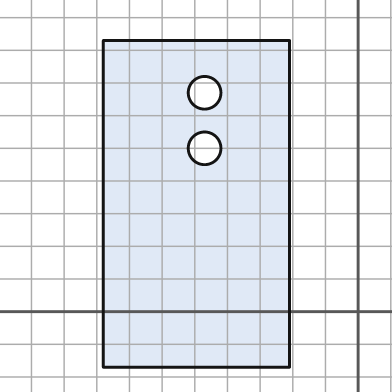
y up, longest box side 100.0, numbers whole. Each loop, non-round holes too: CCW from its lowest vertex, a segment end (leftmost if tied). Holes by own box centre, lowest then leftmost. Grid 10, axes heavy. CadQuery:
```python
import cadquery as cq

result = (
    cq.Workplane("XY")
    .moveTo(-78.0, -17.0)
    .lineTo(-21.0, -17.0)
    .lineTo(-21.0, 83.0)
    .lineTo(-78.0, 83.0)
    .close()
    .moveTo(-47.0, 50.0)
    .circle(5.0)
    .moveTo(-47.0, 67.0)
    .circle(5.0)
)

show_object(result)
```